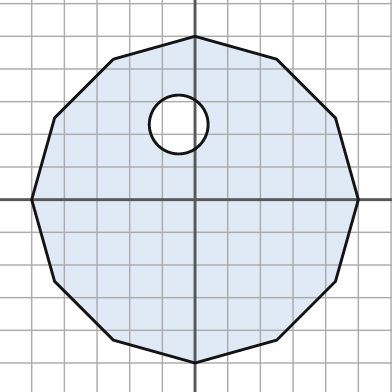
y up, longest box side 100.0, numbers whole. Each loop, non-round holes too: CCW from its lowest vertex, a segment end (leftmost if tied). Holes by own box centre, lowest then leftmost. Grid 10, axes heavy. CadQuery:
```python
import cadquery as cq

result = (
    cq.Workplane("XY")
    .moveTo(0.0, -50.0)
    .lineTo(25.0, -43.0)
    .lineTo(43.0, -25.0)
    .lineTo(50.0, 0.0)
    .lineTo(43.0, 25.0)
    .lineTo(25.0, 43.0)
    .lineTo(0.0, 50.0)
    .lineTo(-25.0, 43.0)
    .lineTo(-43.0, 25.0)
    .lineTo(-50.0, 0.0)
    .lineTo(-43.0, -25.0)
    .lineTo(-25.0, -43.0)
    .close()
    .moveTo(-5.0, 23.0)
    .circle(9.0)
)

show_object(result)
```